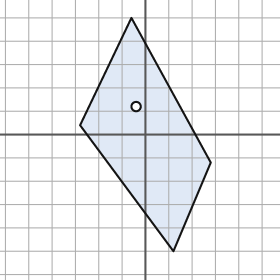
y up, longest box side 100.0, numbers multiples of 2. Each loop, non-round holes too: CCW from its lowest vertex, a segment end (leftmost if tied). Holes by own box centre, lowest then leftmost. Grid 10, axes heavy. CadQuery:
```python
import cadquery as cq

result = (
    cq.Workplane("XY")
    .moveTo(12.0, -50.0)
    .lineTo(28.0, -12.0)
    .lineTo(-6.0, 50.0)
    .lineTo(-28.0, 4.0)
    .close()
    .moveTo(-4.0, 12.0)
    .circle(2.0)
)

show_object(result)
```